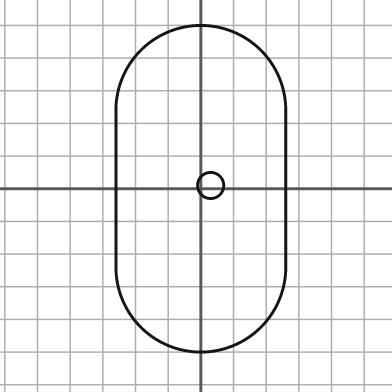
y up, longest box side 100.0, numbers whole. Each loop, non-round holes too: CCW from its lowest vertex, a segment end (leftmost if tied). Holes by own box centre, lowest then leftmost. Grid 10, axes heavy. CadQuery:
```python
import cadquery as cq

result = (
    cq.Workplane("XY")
    .moveTo(-26.0, -24.0)
    .threePointArc((0.0, -50.0), (26.0, -24.0))
    .lineTo(26.0, 24.0)
    .threePointArc((0.0, 50.0), (-26.0, 24.0))
    .close()
    .moveTo(3.0, 1.0)
    .circle(4.0)
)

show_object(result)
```